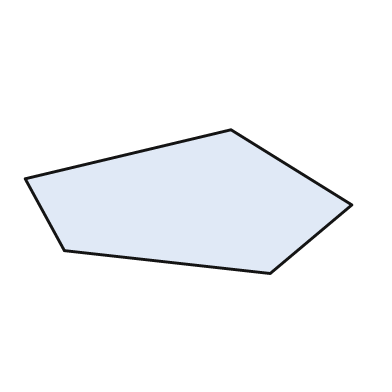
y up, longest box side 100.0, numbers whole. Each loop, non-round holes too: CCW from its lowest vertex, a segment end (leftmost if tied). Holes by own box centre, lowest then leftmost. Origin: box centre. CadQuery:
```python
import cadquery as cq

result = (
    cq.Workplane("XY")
    .moveTo(25.0, -22.0)
    .lineTo(50.0, -1.0)
    .lineTo(13.0, 22.0)
    .lineTo(-50.0, 7.0)
    .lineTo(-38.0, -15.0)
    .close()
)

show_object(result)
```